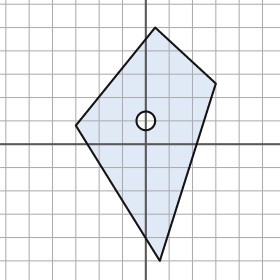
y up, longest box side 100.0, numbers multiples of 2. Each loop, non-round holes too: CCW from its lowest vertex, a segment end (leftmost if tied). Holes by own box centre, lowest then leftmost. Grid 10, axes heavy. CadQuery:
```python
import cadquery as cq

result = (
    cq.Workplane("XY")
    .moveTo(6.0, -50.0)
    .lineTo(30.0, 26.0)
    .lineTo(4.0, 50.0)
    .lineTo(-30.0, 8.0)
    .close()
    .moveTo(0.0, 10.0)
    .circle(4.0)
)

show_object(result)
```